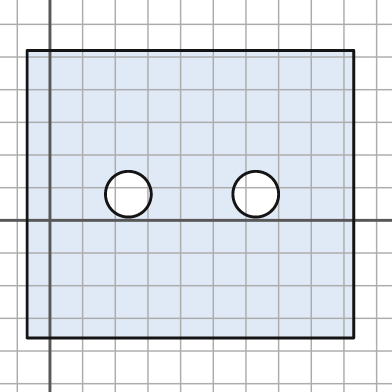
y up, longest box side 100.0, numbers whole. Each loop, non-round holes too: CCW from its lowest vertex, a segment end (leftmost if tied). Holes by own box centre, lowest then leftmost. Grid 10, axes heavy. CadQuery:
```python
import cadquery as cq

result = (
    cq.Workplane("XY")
    .moveTo(-7.0, -36.0)
    .lineTo(93.0, -36.0)
    .lineTo(93.0, 52.0)
    .lineTo(-7.0, 52.0)
    .close()
    .moveTo(24.0, 8.0)
    .circle(7.0)
    .moveTo(63.0, 8.0)
    .circle(7.0)
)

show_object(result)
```